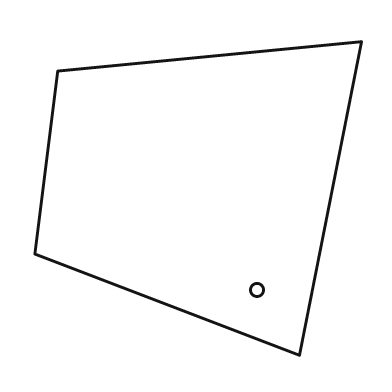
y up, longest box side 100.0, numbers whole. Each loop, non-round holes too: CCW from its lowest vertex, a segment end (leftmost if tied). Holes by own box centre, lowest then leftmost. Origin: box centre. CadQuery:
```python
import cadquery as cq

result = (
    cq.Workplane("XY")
    .moveTo(31.0, -48.0)
    .lineTo(50.0, 48.0)
    .lineTo(-43.0, 39.0)
    .lineTo(-50.0, -17.0)
    .close()
    .moveTo(18.0, -28.0)
    .circle(2.0)
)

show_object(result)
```